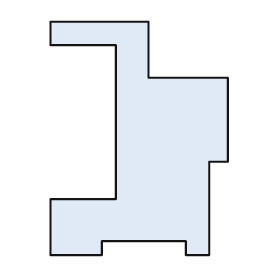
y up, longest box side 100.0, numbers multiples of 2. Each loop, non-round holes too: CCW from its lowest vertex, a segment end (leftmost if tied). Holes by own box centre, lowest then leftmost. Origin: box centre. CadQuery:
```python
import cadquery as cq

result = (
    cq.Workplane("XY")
    .moveTo(-38.0, -50.0)
    .lineTo(-16.0, -50.0)
    .lineTo(-16.0, -44.0)
    .lineTo(20.0, -44.0)
    .lineTo(20.0, -50.0)
    .lineTo(30.0, -50.0)
    .lineTo(30.0, -10.0)
    .lineTo(38.0, -10.0)
    .lineTo(38.0, 26.0)
    .lineTo(4.0, 26.0)
    .lineTo(4.0, 50.0)
    .lineTo(-38.0, 50.0)
    .lineTo(-38.0, 40.0)
    .lineTo(-10.0, 40.0)
    .lineTo(-10.0, -26.0)
    .lineTo(-38.0, -26.0)
    .close()
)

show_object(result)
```